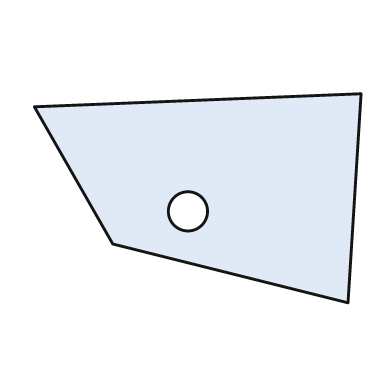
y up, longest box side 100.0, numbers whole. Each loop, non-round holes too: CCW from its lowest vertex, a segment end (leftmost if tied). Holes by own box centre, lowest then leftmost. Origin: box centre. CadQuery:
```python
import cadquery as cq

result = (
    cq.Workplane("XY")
    .moveTo(46.0, -32.0)
    .lineTo(50.0, 32.0)
    .lineTo(-50.0, 28.0)
    .lineTo(-26.0, -14.0)
    .close()
    .moveTo(-3.0, -4.0)
    .circle(6.0)
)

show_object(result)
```